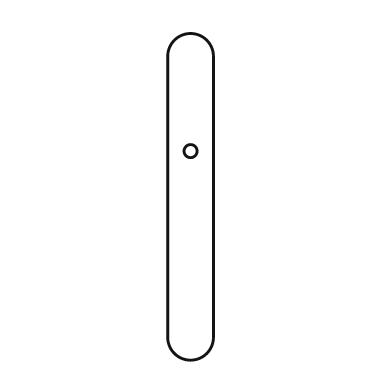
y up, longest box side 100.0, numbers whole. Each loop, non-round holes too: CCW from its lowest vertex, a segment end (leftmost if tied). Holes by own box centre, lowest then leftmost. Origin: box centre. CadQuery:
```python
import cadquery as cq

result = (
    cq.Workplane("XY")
    .moveTo(-7.0, -43.0)
    .threePointArc((0.0, -50.0), (7.0, -43.0))
    .lineTo(7.0, 43.0)
    .threePointArc((0.0, 50.0), (-7.0, 43.0))
    .close()
    .moveTo(0.0, 14.0)
    .circle(2.0)
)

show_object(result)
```